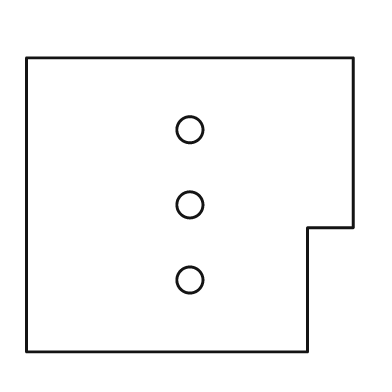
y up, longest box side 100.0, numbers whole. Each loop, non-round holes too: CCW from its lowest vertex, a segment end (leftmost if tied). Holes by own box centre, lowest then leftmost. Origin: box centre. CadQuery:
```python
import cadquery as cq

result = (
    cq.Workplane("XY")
    .moveTo(-50.0, -45.0)
    .lineTo(36.0, -45.0)
    .lineTo(36.0, -7.0)
    .lineTo(50.0, -7.0)
    .lineTo(50.0, 45.0)
    .lineTo(-50.0, 45.0)
    .close()
    .moveTo(0.0, -23.0)
    .circle(4.0)
    .moveTo(0.0, 0.0)
    .circle(4.0)
    .moveTo(0.0, 23.0)
    .circle(4.0)
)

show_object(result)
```